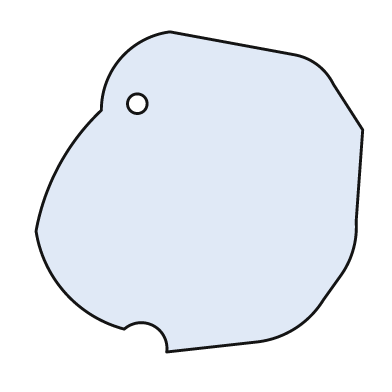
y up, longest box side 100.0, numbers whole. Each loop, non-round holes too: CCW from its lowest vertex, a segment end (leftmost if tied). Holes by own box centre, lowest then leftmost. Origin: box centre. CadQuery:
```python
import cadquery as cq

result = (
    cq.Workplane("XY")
    .moveTo(-10.0, -49.0)
    .lineTo(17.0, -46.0)
    .threePointArc((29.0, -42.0), (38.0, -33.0))
    .lineTo(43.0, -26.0)
    .threePointArc((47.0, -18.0), (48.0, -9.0))
    .lineTo(50.0, 19.0)
    .lineTo(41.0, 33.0)
    .threePointArc((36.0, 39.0), (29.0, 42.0))
    .lineTo(-9.0, 49.0)
    .threePointArc((-24.0, 41.0), (-30.0, 25.0))
    .threePointArc((-43.0, 8.0), (-50.0, -12.0))
    .threePointArc((-41.0, -31.0), (-23.0, -42.0))
    .threePointArc((-14.0, -41.0), (-10.0, -49.0))
    .close()
    .moveTo(-19.0, 27.0)
    .circle(3.0)
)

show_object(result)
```